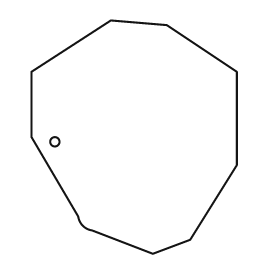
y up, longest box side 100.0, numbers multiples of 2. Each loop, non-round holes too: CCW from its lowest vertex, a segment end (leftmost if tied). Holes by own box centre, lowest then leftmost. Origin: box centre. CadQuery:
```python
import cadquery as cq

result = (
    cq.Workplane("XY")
    .moveTo(8.0, -50.0)
    .lineTo(24.0, -44.0)
    .lineTo(44.0, -12.0)
    .lineTo(44.0, 28.0)
    .lineTo(14.0, 48.0)
    .lineTo(-10.0, 50.0)
    .lineTo(-44.0, 28.0)
    .lineTo(-44.0, 0.0)
    .lineTo(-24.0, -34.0)
    .threePointArc((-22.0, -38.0), (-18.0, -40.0))
    .close()
    .moveTo(-34.0, -2.0)
    .circle(2.0)
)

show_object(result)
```